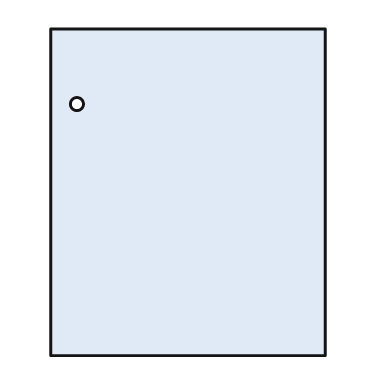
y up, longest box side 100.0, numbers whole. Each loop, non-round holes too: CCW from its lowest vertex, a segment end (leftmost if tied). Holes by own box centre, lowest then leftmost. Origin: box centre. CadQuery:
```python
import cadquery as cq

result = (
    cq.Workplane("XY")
    .moveTo(-42.0, -50.0)
    .lineTo(42.0, -50.0)
    .lineTo(42.0, 50.0)
    .lineTo(-42.0, 50.0)
    .close()
    .moveTo(-34.0, 27.0)
    .circle(2.0)
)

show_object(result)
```